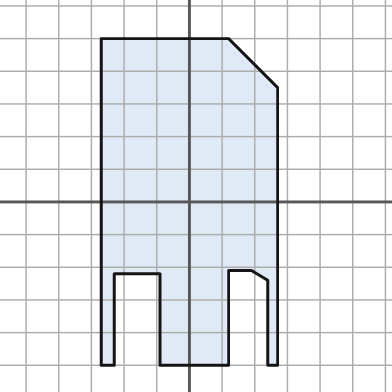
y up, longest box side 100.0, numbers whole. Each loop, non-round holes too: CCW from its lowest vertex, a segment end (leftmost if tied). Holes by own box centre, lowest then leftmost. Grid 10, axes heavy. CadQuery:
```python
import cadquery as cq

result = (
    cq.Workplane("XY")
    .moveTo(-27.0, -50.0)
    .lineTo(-23.0, -50.0)
    .lineTo(-23.0, -22.0)
    .lineTo(-9.0, -22.0)
    .lineTo(-9.0, -50.0)
    .lineTo(12.0, -50.0)
    .lineTo(12.0, -21.0)
    .lineTo(19.0, -21.0)
    .lineTo(24.0, -24.0)
    .lineTo(24.0, -50.0)
    .lineTo(27.0, -50.0)
    .lineTo(27.0, 35.0)
    .lineTo(12.0, 50.0)
    .lineTo(-27.0, 50.0)
    .close()
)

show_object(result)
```